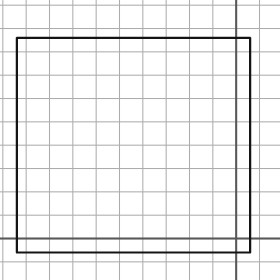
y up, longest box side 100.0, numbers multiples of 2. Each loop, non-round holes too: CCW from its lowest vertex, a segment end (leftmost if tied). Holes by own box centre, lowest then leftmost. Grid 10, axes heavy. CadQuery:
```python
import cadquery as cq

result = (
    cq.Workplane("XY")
    .moveTo(-94.0, -6.0)
    .lineTo(6.0, -6.0)
    .lineTo(6.0, 86.0)
    .lineTo(-94.0, 86.0)
    .close()
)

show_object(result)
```